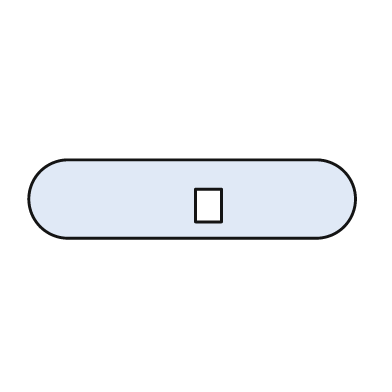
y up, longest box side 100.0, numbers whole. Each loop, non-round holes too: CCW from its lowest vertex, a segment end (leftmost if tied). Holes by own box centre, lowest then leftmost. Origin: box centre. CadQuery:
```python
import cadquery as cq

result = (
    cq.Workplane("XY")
    .moveTo(-38.0, -12.0)
    .lineTo(38.0, -12.0)
    .threePointArc((50.0, 0.0), (38.0, 12.0))
    .lineTo(-38.0, 12.0)
    .threePointArc((-50.0, 0.0), (-38.0, -12.0))
    .close()
    .moveTo(1.0, -7.0)
    .lineTo(9.0, -7.0)
    .lineTo(9.0, 3.0)
    .lineTo(1.0, 3.0)
    .close()
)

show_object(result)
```